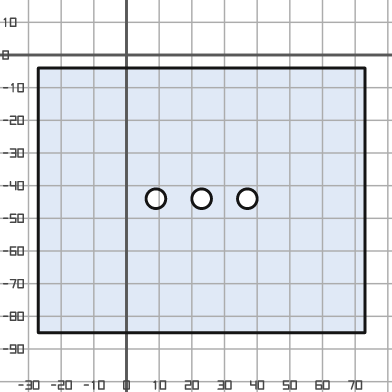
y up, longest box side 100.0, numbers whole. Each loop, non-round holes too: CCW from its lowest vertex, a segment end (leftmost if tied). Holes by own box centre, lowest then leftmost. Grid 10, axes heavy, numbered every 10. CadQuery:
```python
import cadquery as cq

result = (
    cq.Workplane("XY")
    .moveTo(-27.0, -85.0)
    .lineTo(73.0, -85.0)
    .lineTo(73.0, -4.0)
    .lineTo(-27.0, -4.0)
    .close()
    .moveTo(9.0, -44.0)
    .circle(3.0)
    .moveTo(23.0, -44.0)
    .circle(3.0)
    .moveTo(37.0, -44.0)
    .circle(3.0)
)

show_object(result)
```